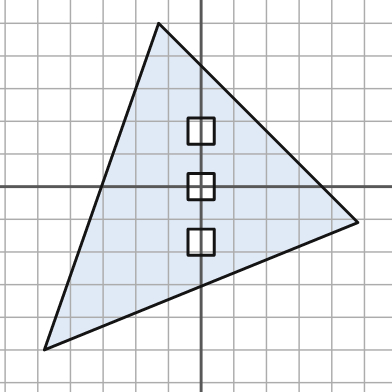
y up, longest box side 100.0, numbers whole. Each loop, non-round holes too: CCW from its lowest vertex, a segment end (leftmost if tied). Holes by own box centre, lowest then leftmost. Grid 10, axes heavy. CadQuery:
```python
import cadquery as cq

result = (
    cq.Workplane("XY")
    .moveTo(-48.0, -50.0)
    .lineTo(48.0, -11.0)
    .lineTo(-13.0, 50.0)
    .close()
    .moveTo(-4.0, -21.0)
    .lineTo(4.0, -21.0)
    .lineTo(4.0, -13.0)
    .lineTo(-4.0, -13.0)
    .close()
    .moveTo(-4.0, -4.0)
    .lineTo(4.0, -4.0)
    .lineTo(4.0, 4.0)
    .lineTo(-4.0, 4.0)
    .close()
    .moveTo(-4.0, 13.0)
    .lineTo(4.0, 13.0)
    .lineTo(4.0, 21.0)
    .lineTo(-4.0, 21.0)
    .close()
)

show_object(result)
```